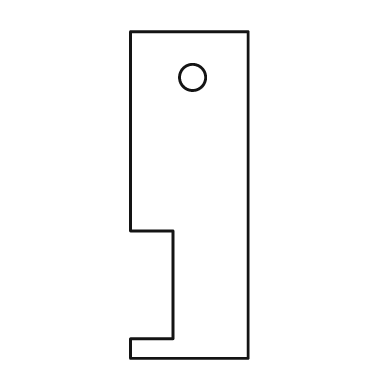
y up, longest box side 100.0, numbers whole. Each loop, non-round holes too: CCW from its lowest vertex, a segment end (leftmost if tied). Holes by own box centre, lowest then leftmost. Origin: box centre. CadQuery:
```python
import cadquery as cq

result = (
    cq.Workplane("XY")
    .moveTo(-18.0, -50.0)
    .lineTo(18.0, -50.0)
    .lineTo(18.0, 50.0)
    .lineTo(-18.0, 50.0)
    .lineTo(-18.0, -11.0)
    .lineTo(-5.0, -11.0)
    .lineTo(-5.0, -44.0)
    .lineTo(-18.0, -44.0)
    .close()
    .moveTo(1.0, 36.0)
    .circle(4.0)
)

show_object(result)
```